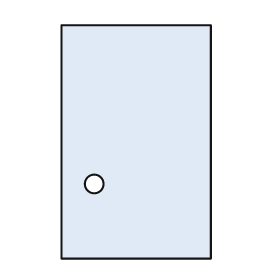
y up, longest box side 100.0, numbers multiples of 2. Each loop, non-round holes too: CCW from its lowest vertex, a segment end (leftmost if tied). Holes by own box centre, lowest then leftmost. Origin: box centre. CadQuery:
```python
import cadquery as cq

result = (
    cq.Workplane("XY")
    .moveTo(-32.0, -50.0)
    .lineTo(32.0, -50.0)
    .lineTo(32.0, 50.0)
    .lineTo(-32.0, 50.0)
    .close()
    .moveTo(-18.0, -18.0)
    .circle(4.0)
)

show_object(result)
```